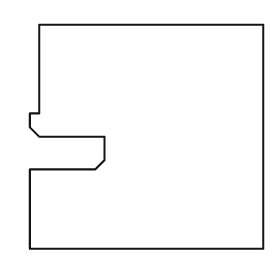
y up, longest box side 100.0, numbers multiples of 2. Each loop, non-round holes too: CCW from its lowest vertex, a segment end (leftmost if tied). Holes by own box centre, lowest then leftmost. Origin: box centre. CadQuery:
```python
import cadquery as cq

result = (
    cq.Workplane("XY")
    .moveTo(-50.0, -48.0)
    .lineTo(50.0, -48.0)
    .lineTo(50.0, 48.0)
    .lineTo(-46.0, 48.0)
    .lineTo(-46.0, 10.0)
    .lineTo(-50.0, 10.0)
    .lineTo(-50.0, 4.0)
    .lineTo(-46.0, 0.0)
    .lineTo(-18.0, 0.0)
    .lineTo(-18.0, -10.0)
    .lineTo(-22.0, -14.0)
    .lineTo(-50.0, -14.0)
    .close()
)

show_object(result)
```